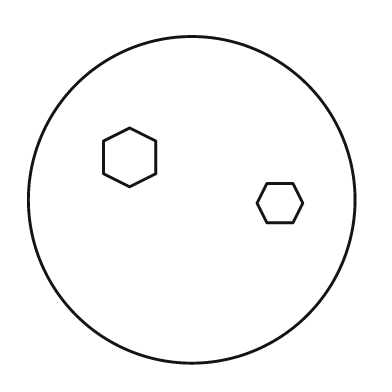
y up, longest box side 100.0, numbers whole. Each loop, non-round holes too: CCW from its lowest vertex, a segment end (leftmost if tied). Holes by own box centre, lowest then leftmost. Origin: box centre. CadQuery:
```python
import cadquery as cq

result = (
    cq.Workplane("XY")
    .moveTo(0.0, 0.0)
    .circle(50.0)
    .moveTo(23.0, -7.0)
    .lineTo(31.0, -7.0)
    .lineTo(34.0, -1.0)
    .lineTo(31.0, 5.0)
    .lineTo(23.0, 5.0)
    .lineTo(20.0, -1.0)
    .close()
    .moveTo(-19.0, 4.0)
    .lineTo(-11.0, 8.0)
    .lineTo(-11.0, 18.0)
    .lineTo(-19.0, 22.0)
    .lineTo(-27.0, 18.0)
    .lineTo(-27.0, 8.0)
    .close()
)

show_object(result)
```